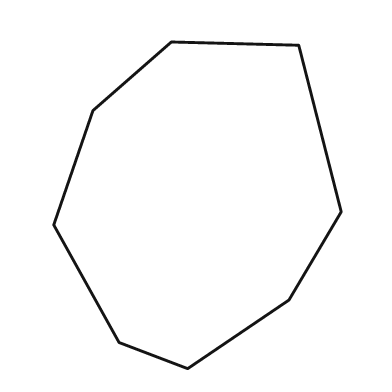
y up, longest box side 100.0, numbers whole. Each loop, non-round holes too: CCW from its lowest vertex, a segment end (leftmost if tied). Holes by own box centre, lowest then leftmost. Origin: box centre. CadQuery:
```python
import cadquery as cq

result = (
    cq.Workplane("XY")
    .moveTo(-3.0, -50.0)
    .lineTo(28.0, -29.0)
    .lineTo(44.0, -2.0)
    .lineTo(31.0, 49.0)
    .lineTo(-8.0, 50.0)
    .lineTo(-32.0, 29.0)
    .lineTo(-44.0, -6.0)
    .lineTo(-24.0, -42.0)
    .close()
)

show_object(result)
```